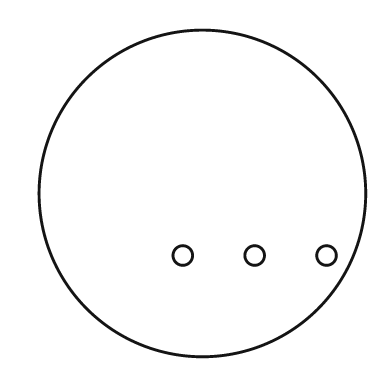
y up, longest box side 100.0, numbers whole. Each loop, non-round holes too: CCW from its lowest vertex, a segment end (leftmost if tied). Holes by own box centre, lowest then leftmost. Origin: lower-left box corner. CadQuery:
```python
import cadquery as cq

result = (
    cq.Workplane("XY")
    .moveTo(50.0, 50.0)
    .circle(50.0)
    .moveTo(44.0, 31.0)
    .circle(3.0)
    .moveTo(66.0, 31.0)
    .circle(3.0)
    .moveTo(88.0, 31.0)
    .circle(3.0)
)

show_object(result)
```